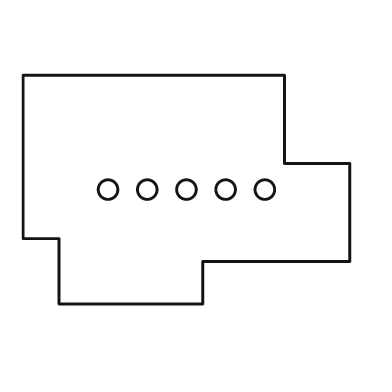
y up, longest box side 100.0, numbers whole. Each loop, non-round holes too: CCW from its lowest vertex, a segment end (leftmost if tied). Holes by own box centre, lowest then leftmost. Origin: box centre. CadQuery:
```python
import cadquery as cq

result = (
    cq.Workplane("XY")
    .moveTo(-39.0, -35.0)
    .lineTo(5.0, -35.0)
    .lineTo(5.0, -22.0)
    .lineTo(50.0, -22.0)
    .lineTo(50.0, 8.0)
    .lineTo(30.0, 8.0)
    .lineTo(30.0, 35.0)
    .lineTo(-50.0, 35.0)
    .lineTo(-50.0, -15.0)
    .lineTo(-39.0, -15.0)
    .close()
    .moveTo(-24.0, 0.0)
    .circle(3.0)
    .moveTo(-12.0, 0.0)
    .circle(3.0)
    .moveTo(0.0, 0.0)
    .circle(3.0)
    .moveTo(12.0, 0.0)
    .circle(3.0)
    .moveTo(24.0, 0.0)
    .circle(3.0)
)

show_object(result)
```